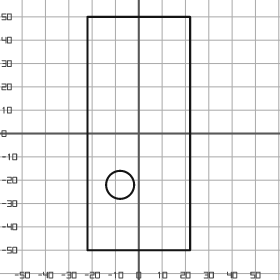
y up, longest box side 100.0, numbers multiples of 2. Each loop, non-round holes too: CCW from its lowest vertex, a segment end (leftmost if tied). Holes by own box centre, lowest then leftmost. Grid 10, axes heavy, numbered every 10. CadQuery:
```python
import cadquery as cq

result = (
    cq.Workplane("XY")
    .moveTo(-22.0, -50.0)
    .lineTo(22.0, -50.0)
    .lineTo(22.0, 50.0)
    .lineTo(-22.0, 50.0)
    .close()
    .moveTo(-8.0, -22.0)
    .circle(6.0)
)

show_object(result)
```